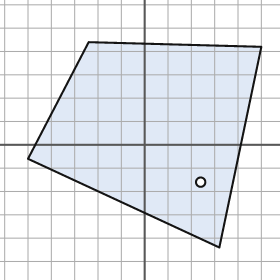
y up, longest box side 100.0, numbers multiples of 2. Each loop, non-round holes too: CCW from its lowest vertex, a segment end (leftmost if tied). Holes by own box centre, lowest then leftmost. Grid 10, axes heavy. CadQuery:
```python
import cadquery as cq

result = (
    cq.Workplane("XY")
    .moveTo(32.0, -44.0)
    .lineTo(50.0, 42.0)
    .lineTo(-24.0, 44.0)
    .lineTo(-50.0, -6.0)
    .close()
    .moveTo(24.0, -16.0)
    .circle(2.0)
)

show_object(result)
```